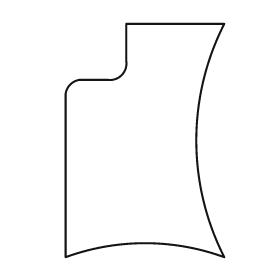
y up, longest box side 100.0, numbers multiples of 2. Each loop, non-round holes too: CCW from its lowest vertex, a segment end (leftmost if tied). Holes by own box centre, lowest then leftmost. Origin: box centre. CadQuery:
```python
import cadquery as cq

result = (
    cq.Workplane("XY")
    .moveTo(-34.0, -50.0)
    .threePointArc((0.0, -44.0), (34.0, -50.0))
    .threePointArc((22.0, 0.0), (34.0, 50.0))
    .lineTo(-8.0, 50.0)
    .lineTo(-8.0, 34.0)
    .threePointArc((-10.0, 28.0), (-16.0, 26.0))
    .lineTo(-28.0, 26.0)
    .threePointArc((-32.0, 24.0), (-34.0, 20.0))
    .close()
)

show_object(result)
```